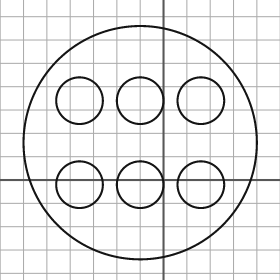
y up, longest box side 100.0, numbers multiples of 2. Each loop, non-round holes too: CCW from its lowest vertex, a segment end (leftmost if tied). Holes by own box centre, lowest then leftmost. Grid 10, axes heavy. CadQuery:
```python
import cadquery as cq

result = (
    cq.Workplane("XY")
    .moveTo(-10.0, 16.0)
    .circle(50.0)
    .moveTo(-36.0, -2.0)
    .circle(10.0)
    .moveTo(-10.0, -2.0)
    .circle(10.0)
    .moveTo(16.0, -2.0)
    .circle(10.0)
    .moveTo(-36.0, 34.0)
    .circle(10.0)
    .moveTo(-10.0, 34.0)
    .circle(10.0)
    .moveTo(16.0, 34.0)
    .circle(10.0)
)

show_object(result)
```